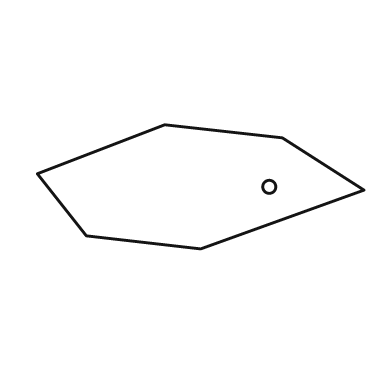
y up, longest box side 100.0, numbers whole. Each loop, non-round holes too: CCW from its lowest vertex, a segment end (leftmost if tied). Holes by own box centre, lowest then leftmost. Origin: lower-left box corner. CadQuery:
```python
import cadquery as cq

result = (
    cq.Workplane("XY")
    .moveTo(50.0, 0.0)
    .lineTo(100.0, 18.0)
    .lineTo(75.0, 34.0)
    .lineTo(39.0, 38.0)
    .lineTo(0.0, 23.0)
    .lineTo(15.0, 4.0)
    .close()
    .moveTo(71.0, 19.0)
    .circle(2.0)
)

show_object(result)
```